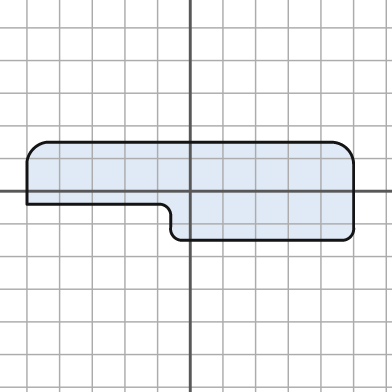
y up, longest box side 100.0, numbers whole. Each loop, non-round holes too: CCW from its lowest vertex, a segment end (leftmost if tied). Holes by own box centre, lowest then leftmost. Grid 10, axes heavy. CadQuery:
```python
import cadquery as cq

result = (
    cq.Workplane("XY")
    .moveTo(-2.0, -15.0)
    .lineTo(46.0, -15.0)
    .threePointArc((49.0, -14.0), (50.0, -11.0))
    .lineTo(50.0, 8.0)
    .threePointArc((48.0, 13.0), (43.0, 15.0))
    .lineTo(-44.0, 15.0)
    .threePointArc((-48.0, 13.0), (-50.0, 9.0))
    .lineTo(-50.0, -4.0)
    .lineTo(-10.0, -4.0)
    .threePointArc((-7.0, -5.0), (-6.0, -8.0))
    .lineTo(-6.0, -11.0)
    .threePointArc((-5.0, -14.0), (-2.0, -15.0))
    .close()
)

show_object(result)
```